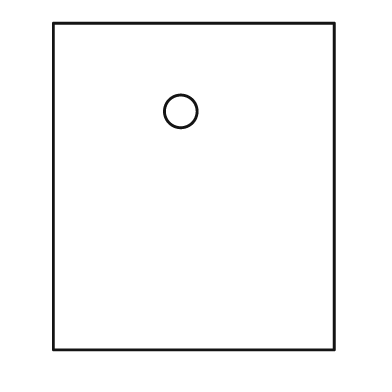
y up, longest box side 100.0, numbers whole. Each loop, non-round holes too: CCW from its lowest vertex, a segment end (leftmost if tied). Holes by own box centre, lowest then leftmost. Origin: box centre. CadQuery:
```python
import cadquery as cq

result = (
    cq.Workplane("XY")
    .moveTo(-43.0, -50.0)
    .lineTo(43.0, -50.0)
    .lineTo(43.0, 50.0)
    .lineTo(-43.0, 50.0)
    .close()
    .moveTo(-4.0, 23.0)
    .circle(5.0)
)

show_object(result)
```